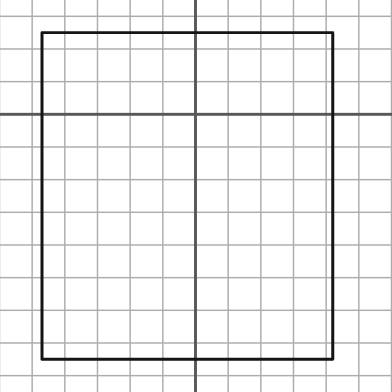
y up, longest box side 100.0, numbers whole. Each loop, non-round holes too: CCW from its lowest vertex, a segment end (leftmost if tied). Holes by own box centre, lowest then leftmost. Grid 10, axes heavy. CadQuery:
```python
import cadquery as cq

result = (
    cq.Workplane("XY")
    .moveTo(-47.0, -75.0)
    .lineTo(42.0, -75.0)
    .lineTo(42.0, 25.0)
    .lineTo(-47.0, 25.0)
    .close()
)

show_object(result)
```